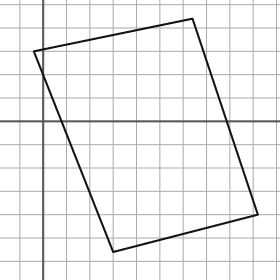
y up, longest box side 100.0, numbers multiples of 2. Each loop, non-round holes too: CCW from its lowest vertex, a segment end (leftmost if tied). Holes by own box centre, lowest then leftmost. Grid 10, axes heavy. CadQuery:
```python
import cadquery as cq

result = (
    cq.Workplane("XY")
    .moveTo(30.0, -56.0)
    .lineTo(92.0, -40.0)
    .lineTo(64.0, 44.0)
    .lineTo(-4.0, 30.0)
    .close()
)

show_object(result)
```